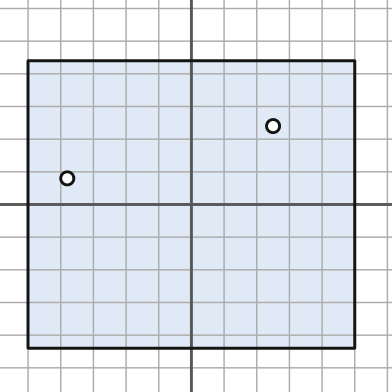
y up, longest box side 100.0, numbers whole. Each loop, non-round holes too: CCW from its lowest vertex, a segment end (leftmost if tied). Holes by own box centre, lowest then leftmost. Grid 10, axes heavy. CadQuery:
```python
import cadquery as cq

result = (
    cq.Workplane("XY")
    .moveTo(-50.0, -44.0)
    .lineTo(50.0, -44.0)
    .lineTo(50.0, 44.0)
    .lineTo(-50.0, 44.0)
    .close()
    .moveTo(-38.0, 8.0)
    .circle(2.0)
    .moveTo(25.0, 24.0)
    .circle(2.0)
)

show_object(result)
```